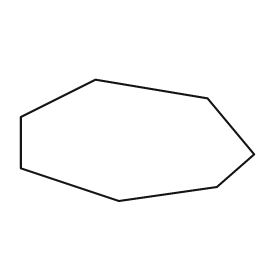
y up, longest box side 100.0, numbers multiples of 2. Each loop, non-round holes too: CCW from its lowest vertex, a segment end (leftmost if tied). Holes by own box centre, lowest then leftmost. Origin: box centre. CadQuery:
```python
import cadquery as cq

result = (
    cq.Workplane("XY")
    .moveTo(-8.0, -26.0)
    .lineTo(34.0, -20.0)
    .lineTo(50.0, -6.0)
    .lineTo(30.0, 18.0)
    .lineTo(-18.0, 26.0)
    .lineTo(-50.0, 10.0)
    .lineTo(-50.0, -12.0)
    .close()
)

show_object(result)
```